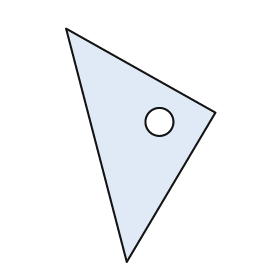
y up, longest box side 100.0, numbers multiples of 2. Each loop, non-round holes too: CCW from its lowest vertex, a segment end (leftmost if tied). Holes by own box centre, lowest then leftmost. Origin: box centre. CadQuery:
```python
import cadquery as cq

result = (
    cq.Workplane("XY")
    .moveTo(-6.0, -50.0)
    .lineTo(32.0, 14.0)
    .lineTo(-32.0, 50.0)
    .close()
    .moveTo(8.0, 10.0)
    .circle(6.0)
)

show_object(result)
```